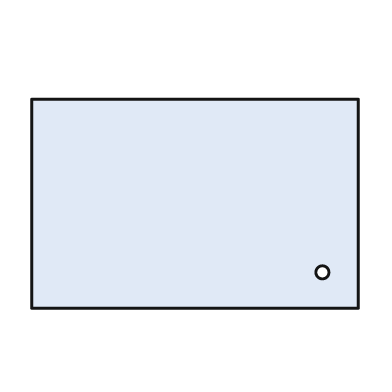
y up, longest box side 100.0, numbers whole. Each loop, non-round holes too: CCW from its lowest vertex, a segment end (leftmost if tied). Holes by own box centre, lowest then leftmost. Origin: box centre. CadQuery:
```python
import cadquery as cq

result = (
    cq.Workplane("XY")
    .moveTo(-50.0, -32.0)
    .lineTo(50.0, -32.0)
    .lineTo(50.0, 32.0)
    .lineTo(-50.0, 32.0)
    .close()
    .moveTo(39.0, -21.0)
    .circle(2.0)
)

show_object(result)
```